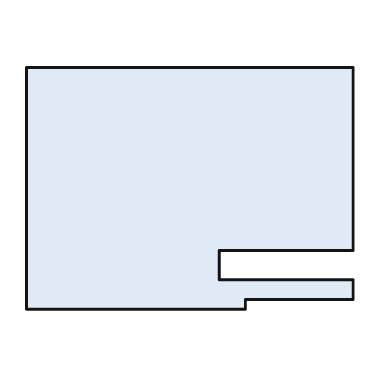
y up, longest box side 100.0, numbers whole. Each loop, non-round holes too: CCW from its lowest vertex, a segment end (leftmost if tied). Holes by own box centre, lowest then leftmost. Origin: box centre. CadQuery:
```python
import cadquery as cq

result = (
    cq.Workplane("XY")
    .moveTo(-50.0, -37.0)
    .lineTo(17.0, -37.0)
    .lineTo(17.0, -34.0)
    .lineTo(50.0, -34.0)
    .lineTo(50.0, -28.0)
    .lineTo(9.0, -28.0)
    .lineTo(9.0, -19.0)
    .lineTo(50.0, -19.0)
    .lineTo(50.0, 37.0)
    .lineTo(-50.0, 37.0)
    .close()
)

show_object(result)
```